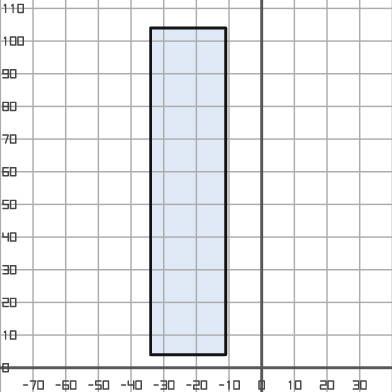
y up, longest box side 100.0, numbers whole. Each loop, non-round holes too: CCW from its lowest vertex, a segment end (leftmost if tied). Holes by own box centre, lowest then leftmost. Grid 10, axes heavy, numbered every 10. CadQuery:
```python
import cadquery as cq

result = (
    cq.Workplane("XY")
    .moveTo(-34.0, 4.0)
    .lineTo(-11.0, 4.0)
    .lineTo(-11.0, 104.0)
    .lineTo(-34.0, 104.0)
    .close()
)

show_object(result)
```